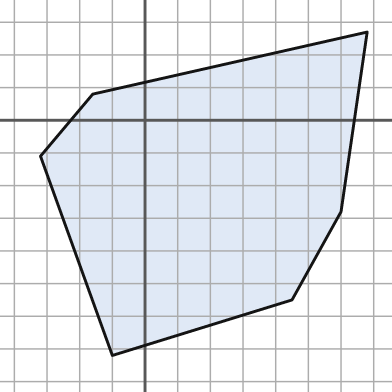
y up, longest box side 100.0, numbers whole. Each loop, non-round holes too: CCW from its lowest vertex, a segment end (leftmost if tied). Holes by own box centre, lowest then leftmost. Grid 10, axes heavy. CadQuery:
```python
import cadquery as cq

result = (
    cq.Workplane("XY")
    .moveTo(-10.0, -72.0)
    .lineTo(45.0, -55.0)
    .lineTo(60.0, -28.0)
    .lineTo(68.0, 27.0)
    .lineTo(-16.0, 8.0)
    .lineTo(-32.0, -11.0)
    .close()
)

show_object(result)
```